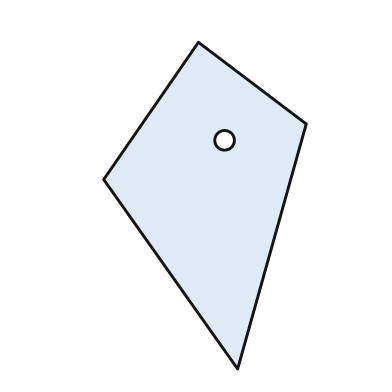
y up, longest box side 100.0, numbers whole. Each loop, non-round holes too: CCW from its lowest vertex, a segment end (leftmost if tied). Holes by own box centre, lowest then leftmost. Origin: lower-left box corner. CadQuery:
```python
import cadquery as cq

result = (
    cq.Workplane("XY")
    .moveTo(41.0, 0.0)
    .lineTo(62.0, 75.0)
    .lineTo(29.0, 100.0)
    .lineTo(0.0, 58.0)
    .close()
    .moveTo(37.0, 70.0)
    .circle(3.0)
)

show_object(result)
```